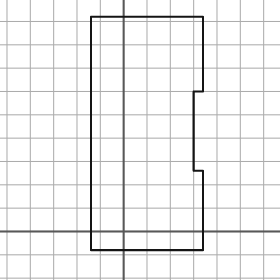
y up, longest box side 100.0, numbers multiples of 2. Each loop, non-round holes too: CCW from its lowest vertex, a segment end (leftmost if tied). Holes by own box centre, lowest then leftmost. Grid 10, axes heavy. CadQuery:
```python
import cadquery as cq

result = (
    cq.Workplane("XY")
    .moveTo(-14.0, -8.0)
    .lineTo(34.0, -8.0)
    .lineTo(34.0, 26.0)
    .lineTo(30.0, 26.0)
    .lineTo(30.0, 60.0)
    .lineTo(34.0, 60.0)
    .lineTo(34.0, 92.0)
    .lineTo(-14.0, 92.0)
    .close()
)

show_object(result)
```